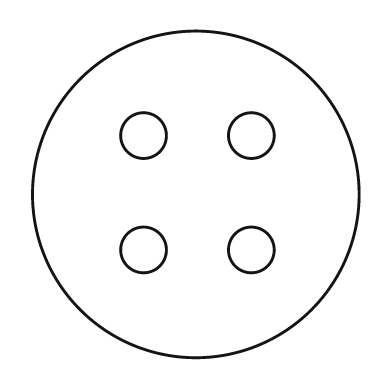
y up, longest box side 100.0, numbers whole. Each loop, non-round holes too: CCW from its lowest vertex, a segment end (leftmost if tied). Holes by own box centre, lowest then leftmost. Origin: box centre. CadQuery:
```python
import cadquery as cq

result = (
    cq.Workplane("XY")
    .moveTo(0.0, 0.0)
    .circle(50.0)
    .moveTo(-16.0, -17.0)
    .circle(7.0)
    .moveTo(17.0, -17.0)
    .circle(7.0)
    .moveTo(-16.0, 18.0)
    .circle(7.0)
    .moveTo(17.0, 18.0)
    .circle(7.0)
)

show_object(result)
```